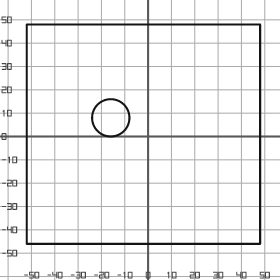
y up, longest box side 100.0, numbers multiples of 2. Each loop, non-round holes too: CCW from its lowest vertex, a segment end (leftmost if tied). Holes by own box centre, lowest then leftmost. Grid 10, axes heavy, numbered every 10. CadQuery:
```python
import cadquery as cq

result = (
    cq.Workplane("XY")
    .moveTo(-52.0, -46.0)
    .lineTo(48.0, -46.0)
    .lineTo(48.0, 48.0)
    .lineTo(-52.0, 48.0)
    .close()
    .moveTo(-16.0, 8.0)
    .circle(8.0)
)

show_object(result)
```